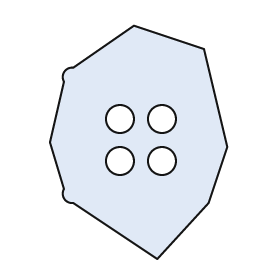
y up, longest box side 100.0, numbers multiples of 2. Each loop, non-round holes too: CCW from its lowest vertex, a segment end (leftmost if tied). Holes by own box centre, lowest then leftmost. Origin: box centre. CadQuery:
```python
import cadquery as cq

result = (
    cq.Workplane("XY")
    .moveTo(8.0, -50.0)
    .lineTo(30.0, -26.0)
    .lineTo(38.0, -2.0)
    .lineTo(28.0, 40.0)
    .lineTo(-2.0, 50.0)
    .lineTo(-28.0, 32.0)
    .threePointArc((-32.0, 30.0), (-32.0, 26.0))
    .lineTo(-38.0, 0.0)
    .lineTo(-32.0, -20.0)
    .threePointArc((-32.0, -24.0), (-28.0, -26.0))
    .close()
    .moveTo(-8.0, -8.0)
    .circle(6.0)
    .moveTo(10.0, -8.0)
    .circle(6.0)
    .moveTo(-8.0, 10.0)
    .circle(6.0)
    .moveTo(10.0, 10.0)
    .circle(6.0)
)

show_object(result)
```